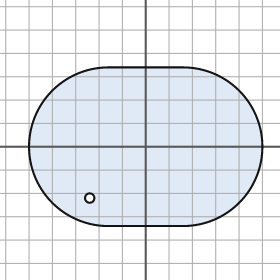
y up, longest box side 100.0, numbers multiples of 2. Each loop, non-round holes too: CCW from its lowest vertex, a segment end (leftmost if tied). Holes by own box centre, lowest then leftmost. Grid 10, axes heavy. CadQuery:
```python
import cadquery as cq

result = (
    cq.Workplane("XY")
    .moveTo(-16.0, -34.0)
    .lineTo(16.0, -34.0)
    .threePointArc((50.0, 0.0), (16.0, 34.0))
    .lineTo(-16.0, 34.0)
    .threePointArc((-50.0, 0.0), (-16.0, -34.0))
    .close()
    .moveTo(-24.0, -22.0)
    .circle(2.0)
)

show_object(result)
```